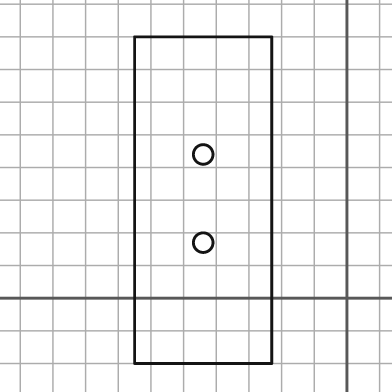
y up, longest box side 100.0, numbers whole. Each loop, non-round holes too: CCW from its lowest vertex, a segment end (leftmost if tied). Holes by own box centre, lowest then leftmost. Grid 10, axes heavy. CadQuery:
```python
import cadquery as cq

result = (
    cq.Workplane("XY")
    .moveTo(-65.0, -20.0)
    .lineTo(-23.0, -20.0)
    .lineTo(-23.0, 80.0)
    .lineTo(-65.0, 80.0)
    .close()
    .moveTo(-44.0, 17.0)
    .circle(3.0)
    .moveTo(-44.0, 44.0)
    .circle(3.0)
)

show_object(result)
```